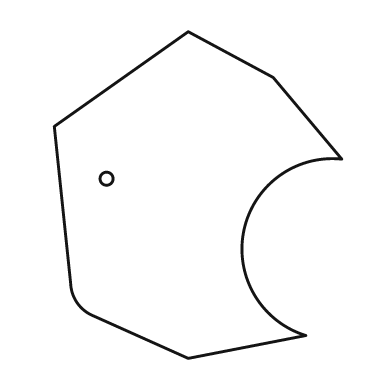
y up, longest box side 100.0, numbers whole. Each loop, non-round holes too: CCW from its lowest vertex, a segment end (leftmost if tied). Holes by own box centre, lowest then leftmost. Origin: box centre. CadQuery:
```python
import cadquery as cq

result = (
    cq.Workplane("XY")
    .moveTo(-3.0, -50.0)
    .lineTo(33.0, -43.0)
    .threePointArc((14.0, -11.0), (44.0, 11.0))
    .lineTo(23.0, 36.0)
    .lineTo(-3.0, 50.0)
    .lineTo(-44.0, 21.0)
    .lineTo(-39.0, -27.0)
    .threePointArc((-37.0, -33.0), (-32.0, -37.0))
    .close()
    .moveTo(-28.0, 5.0)
    .circle(2.0)
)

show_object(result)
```